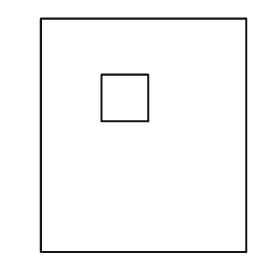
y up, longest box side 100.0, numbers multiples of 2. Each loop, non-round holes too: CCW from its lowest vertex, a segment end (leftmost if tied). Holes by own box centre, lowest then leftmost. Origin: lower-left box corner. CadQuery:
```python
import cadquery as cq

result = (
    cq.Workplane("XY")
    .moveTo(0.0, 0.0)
    .lineTo(88.0, 0.0)
    .lineTo(88.0, 100.0)
    .lineTo(0.0, 100.0)
    .close()
    .moveTo(26.0, 56.0)
    .lineTo(46.0, 56.0)
    .lineTo(46.0, 76.0)
    .lineTo(26.0, 76.0)
    .close()
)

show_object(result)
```